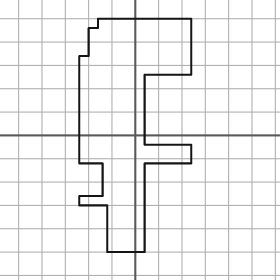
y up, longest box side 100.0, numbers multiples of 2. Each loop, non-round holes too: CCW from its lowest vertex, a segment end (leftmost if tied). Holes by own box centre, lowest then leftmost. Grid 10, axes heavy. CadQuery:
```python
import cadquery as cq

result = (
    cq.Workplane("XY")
    .moveTo(-12.0, -50.0)
    .lineTo(4.0, -50.0)
    .lineTo(4.0, -12.0)
    .lineTo(24.0, -12.0)
    .lineTo(24.0, -4.0)
    .lineTo(4.0, -4.0)
    .lineTo(4.0, 26.0)
    .lineTo(24.0, 26.0)
    .lineTo(24.0, 50.0)
    .lineTo(-16.0, 50.0)
    .lineTo(-16.0, 46.0)
    .lineTo(-20.0, 46.0)
    .lineTo(-20.0, 34.0)
    .lineTo(-24.0, 34.0)
    .lineTo(-24.0, -12.0)
    .lineTo(-14.0, -12.0)
    .lineTo(-14.0, -26.0)
    .lineTo(-24.0, -26.0)
    .lineTo(-24.0, -30.0)
    .lineTo(-12.0, -30.0)
    .close()
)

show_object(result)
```